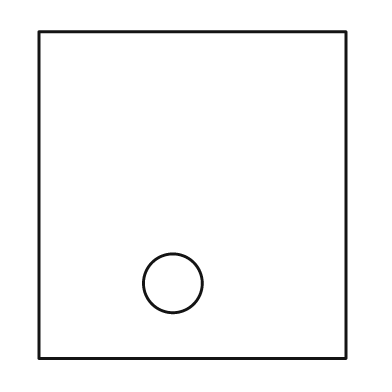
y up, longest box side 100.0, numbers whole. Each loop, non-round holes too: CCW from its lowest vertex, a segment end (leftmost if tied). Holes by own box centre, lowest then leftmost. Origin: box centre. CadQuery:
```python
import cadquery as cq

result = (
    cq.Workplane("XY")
    .moveTo(-47.0, -50.0)
    .lineTo(47.0, -50.0)
    .lineTo(47.0, 50.0)
    .lineTo(-47.0, 50.0)
    .close()
    .moveTo(-6.0, -27.0)
    .circle(9.0)
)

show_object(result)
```